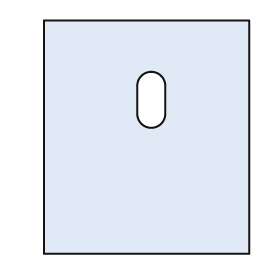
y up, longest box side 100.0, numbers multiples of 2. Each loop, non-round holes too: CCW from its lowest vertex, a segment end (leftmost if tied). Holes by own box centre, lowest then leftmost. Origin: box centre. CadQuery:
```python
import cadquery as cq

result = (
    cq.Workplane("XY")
    .moveTo(-44.0, -50.0)
    .lineTo(44.0, -50.0)
    .lineTo(44.0, 50.0)
    .lineTo(-44.0, 50.0)
    .close()
    .moveTo(-4.0, 10.0)
    .threePointArc((2.0, 4.0), (8.0, 10.0))
    .lineTo(8.0, 22.0)
    .threePointArc((2.0, 28.0), (-4.0, 22.0))
    .close()
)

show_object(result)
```